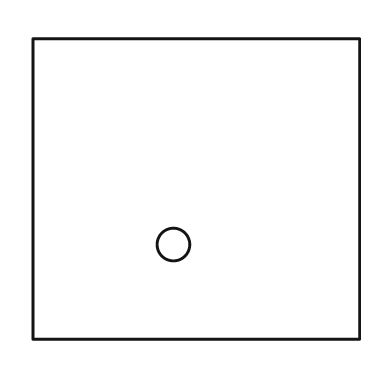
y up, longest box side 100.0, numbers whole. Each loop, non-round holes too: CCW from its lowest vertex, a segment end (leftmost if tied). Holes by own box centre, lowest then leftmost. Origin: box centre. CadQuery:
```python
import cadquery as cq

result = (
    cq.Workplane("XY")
    .moveTo(-50.0, -46.0)
    .lineTo(50.0, -46.0)
    .lineTo(50.0, 46.0)
    .lineTo(-50.0, 46.0)
    .close()
    .moveTo(-7.0, -17.0)
    .circle(5.0)
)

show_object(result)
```